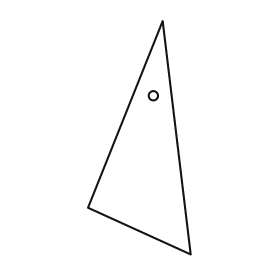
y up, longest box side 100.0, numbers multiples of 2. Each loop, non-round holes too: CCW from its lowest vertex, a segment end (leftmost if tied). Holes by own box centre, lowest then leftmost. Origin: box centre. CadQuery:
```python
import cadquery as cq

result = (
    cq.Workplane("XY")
    .moveTo(22.0, -50.0)
    .lineTo(10.0, 50.0)
    .lineTo(-22.0, -30.0)
    .close()
    .moveTo(6.0, 18.0)
    .circle(2.0)
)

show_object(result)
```